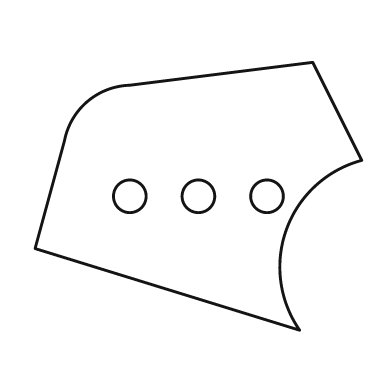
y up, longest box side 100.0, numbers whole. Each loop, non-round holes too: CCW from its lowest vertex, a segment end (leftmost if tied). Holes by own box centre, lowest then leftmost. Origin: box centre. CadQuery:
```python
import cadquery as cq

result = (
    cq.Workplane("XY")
    .moveTo(31.0, -41.0)
    .threePointArc((27.0, -10.0), (50.0, 11.0))
    .lineTo(35.0, 41.0)
    .lineTo(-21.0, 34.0)
    .threePointArc((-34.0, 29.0), (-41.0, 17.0))
    .lineTo(-50.0, -16.0)
    .close()
    .moveTo(-21.0, 0.0)
    .circle(5.0)
    .moveTo(0.0, 0.0)
    .circle(5.0)
    .moveTo(21.0, 0.0)
    .circle(5.0)
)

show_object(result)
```